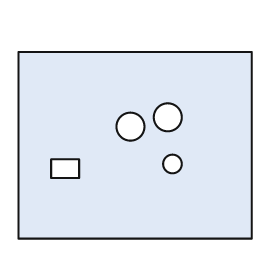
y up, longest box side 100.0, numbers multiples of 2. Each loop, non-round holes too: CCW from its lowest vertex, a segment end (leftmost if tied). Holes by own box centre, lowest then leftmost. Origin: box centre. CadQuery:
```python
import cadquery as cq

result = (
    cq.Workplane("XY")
    .moveTo(-50.0, -40.0)
    .lineTo(50.0, -40.0)
    .lineTo(50.0, 40.0)
    .lineTo(-50.0, 40.0)
    .close()
    .moveTo(-36.0, -14.0)
    .lineTo(-24.0, -14.0)
    .lineTo(-24.0, -6.0)
    .lineTo(-36.0, -6.0)
    .close()
    .moveTo(16.0, -8.0)
    .circle(4.0)
    .moveTo(-2.0, 8.0)
    .circle(6.0)
    .moveTo(14.0, 12.0)
    .circle(6.0)
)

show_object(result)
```